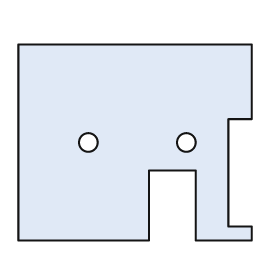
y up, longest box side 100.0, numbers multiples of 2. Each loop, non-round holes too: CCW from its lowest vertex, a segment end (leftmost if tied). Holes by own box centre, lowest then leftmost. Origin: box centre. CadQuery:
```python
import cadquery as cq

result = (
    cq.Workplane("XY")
    .moveTo(-50.0, -42.0)
    .lineTo(6.0, -42.0)
    .lineTo(6.0, -12.0)
    .lineTo(26.0, -12.0)
    .lineTo(26.0, -42.0)
    .lineTo(50.0, -42.0)
    .lineTo(50.0, -36.0)
    .lineTo(40.0, -36.0)
    .lineTo(40.0, 10.0)
    .lineTo(50.0, 10.0)
    .lineTo(50.0, 42.0)
    .lineTo(-50.0, 42.0)
    .close()
    .moveTo(-20.0, 0.0)
    .circle(4.0)
    .moveTo(22.0, 0.0)
    .circle(4.0)
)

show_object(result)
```